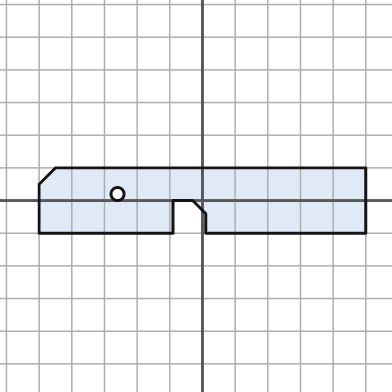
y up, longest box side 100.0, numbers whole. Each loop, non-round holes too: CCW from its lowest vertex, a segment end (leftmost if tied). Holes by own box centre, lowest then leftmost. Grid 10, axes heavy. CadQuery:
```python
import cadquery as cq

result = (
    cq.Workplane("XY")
    .moveTo(-50.0, -10.0)
    .lineTo(-9.0, -10.0)
    .lineTo(-9.0, 0.0)
    .lineTo(-3.0, 0.0)
    .lineTo(1.0, -4.0)
    .lineTo(1.0, -10.0)
    .lineTo(50.0, -10.0)
    .lineTo(50.0, 10.0)
    .lineTo(-45.0, 10.0)
    .lineTo(-50.0, 5.0)
    .close()
    .moveTo(-26.0, 2.0)
    .circle(2.0)
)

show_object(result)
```